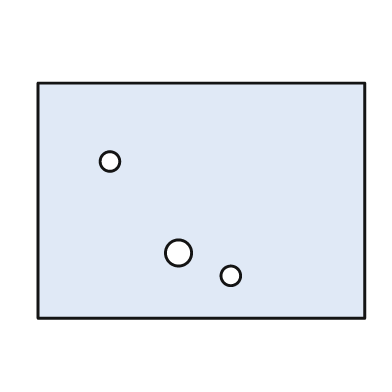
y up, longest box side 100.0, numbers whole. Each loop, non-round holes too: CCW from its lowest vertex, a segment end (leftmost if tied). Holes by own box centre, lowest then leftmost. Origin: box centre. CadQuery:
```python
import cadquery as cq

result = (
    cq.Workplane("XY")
    .moveTo(-50.0, -36.0)
    .lineTo(50.0, -36.0)
    .lineTo(50.0, 36.0)
    .lineTo(-50.0, 36.0)
    .close()
    .moveTo(9.0, -23.0)
    .circle(3.0)
    .moveTo(-7.0, -16.0)
    .circle(4.0)
    .moveTo(-28.0, 12.0)
    .circle(3.0)
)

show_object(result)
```